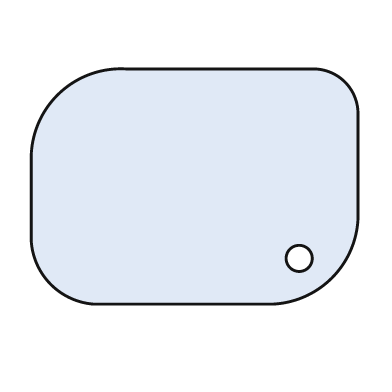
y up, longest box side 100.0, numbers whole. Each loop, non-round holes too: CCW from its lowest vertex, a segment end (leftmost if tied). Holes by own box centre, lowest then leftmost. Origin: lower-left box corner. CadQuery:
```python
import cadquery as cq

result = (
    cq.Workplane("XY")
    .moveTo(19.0, 0.0)
    .lineTo(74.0, 0.0)
    .threePointArc((92.0, 8.0), (100.0, 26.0))
    .lineTo(100.0, 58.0)
    .threePointArc((96.0, 68.0), (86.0, 72.0))
    .lineTo(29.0, 72.0)
    .threePointArc((8.0, 64.0), (0.0, 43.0))
    .lineTo(0.0, 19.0)
    .threePointArc((6.0, 6.0), (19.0, 0.0))
    .close()
    .moveTo(82.0, 14.0)
    .circle(4.0)
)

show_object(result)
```